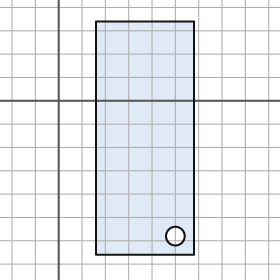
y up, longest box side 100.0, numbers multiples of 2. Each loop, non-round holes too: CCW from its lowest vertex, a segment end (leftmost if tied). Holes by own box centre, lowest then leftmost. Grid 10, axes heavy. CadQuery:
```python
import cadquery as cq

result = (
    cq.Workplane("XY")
    .moveTo(16.0, -66.0)
    .lineTo(58.0, -66.0)
    .lineTo(58.0, 34.0)
    .lineTo(16.0, 34.0)
    .close()
    .moveTo(50.0, -58.0)
    .circle(4.0)
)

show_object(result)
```